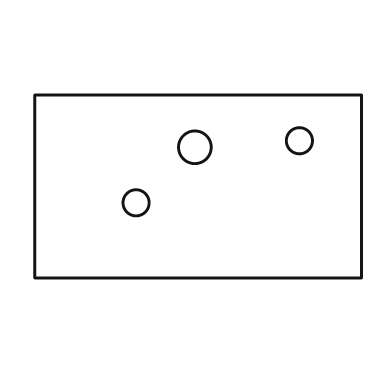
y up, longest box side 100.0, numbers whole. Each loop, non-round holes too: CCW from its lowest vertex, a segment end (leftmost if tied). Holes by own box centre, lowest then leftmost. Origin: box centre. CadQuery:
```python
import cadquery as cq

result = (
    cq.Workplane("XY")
    .moveTo(-50.0, -28.0)
    .lineTo(50.0, -28.0)
    .lineTo(50.0, 28.0)
    .lineTo(-50.0, 28.0)
    .close()
    .moveTo(-19.0, -5.0)
    .circle(4.0)
    .moveTo(-1.0, 12.0)
    .circle(5.0)
    .moveTo(31.0, 14.0)
    .circle(4.0)
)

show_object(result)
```